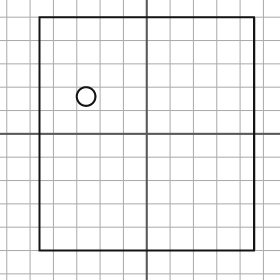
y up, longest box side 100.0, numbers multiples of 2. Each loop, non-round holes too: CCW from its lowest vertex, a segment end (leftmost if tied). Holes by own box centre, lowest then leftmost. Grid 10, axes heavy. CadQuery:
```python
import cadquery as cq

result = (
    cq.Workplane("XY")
    .moveTo(-46.0, -50.0)
    .lineTo(46.0, -50.0)
    .lineTo(46.0, 50.0)
    .lineTo(-46.0, 50.0)
    .close()
    .moveTo(-26.0, 16.0)
    .circle(4.0)
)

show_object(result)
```